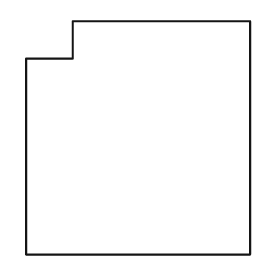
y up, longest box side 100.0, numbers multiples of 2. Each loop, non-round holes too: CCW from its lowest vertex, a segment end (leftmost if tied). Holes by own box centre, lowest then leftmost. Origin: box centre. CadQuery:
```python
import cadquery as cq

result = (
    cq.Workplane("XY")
    .moveTo(-48.0, -50.0)
    .lineTo(48.0, -50.0)
    .lineTo(48.0, 50.0)
    .lineTo(-28.0, 50.0)
    .lineTo(-28.0, 34.0)
    .lineTo(-48.0, 34.0)
    .close()
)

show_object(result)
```